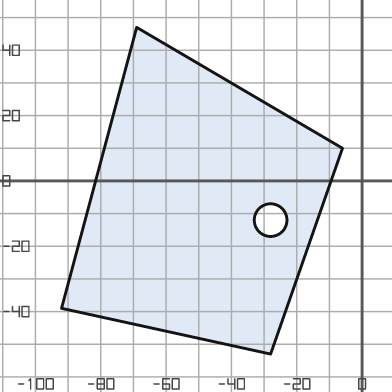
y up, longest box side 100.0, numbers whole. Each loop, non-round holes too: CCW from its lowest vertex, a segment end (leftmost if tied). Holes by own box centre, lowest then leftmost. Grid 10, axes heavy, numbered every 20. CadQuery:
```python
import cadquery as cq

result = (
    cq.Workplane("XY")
    .moveTo(-28.0, -53.0)
    .lineTo(-6.0, 10.0)
    .lineTo(-69.0, 47.0)
    .lineTo(-92.0, -39.0)
    .close()
    .moveTo(-28.0, -12.0)
    .circle(5.0)
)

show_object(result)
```